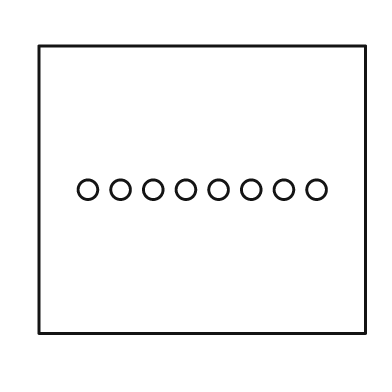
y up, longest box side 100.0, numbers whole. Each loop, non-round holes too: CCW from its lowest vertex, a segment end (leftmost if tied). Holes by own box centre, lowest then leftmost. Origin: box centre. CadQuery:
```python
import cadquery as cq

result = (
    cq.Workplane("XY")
    .moveTo(-50.0, -44.0)
    .lineTo(50.0, -44.0)
    .lineTo(50.0, 44.0)
    .lineTo(-50.0, 44.0)
    .close()
    .moveTo(-35.0, 0.0)
    .circle(3.0)
    .moveTo(-25.0, 0.0)
    .circle(3.0)
    .moveTo(-15.0, 0.0)
    .circle(3.0)
    .moveTo(-5.0, 0.0)
    .circle(3.0)
    .moveTo(5.0, 0.0)
    .circle(3.0)
    .moveTo(15.0, 0.0)
    .circle(3.0)
    .moveTo(25.0, 0.0)
    .circle(3.0)
    .moveTo(35.0, 0.0)
    .circle(3.0)
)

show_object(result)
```